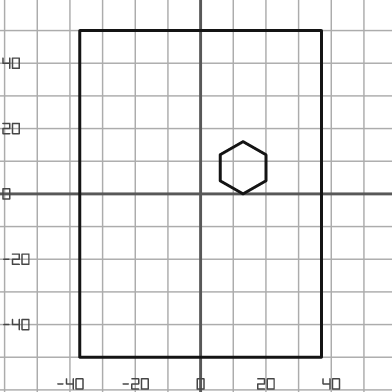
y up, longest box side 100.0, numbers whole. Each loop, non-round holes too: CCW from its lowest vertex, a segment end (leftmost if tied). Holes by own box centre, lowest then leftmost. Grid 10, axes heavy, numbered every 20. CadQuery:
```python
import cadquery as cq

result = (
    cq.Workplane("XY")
    .moveTo(-37.0, -50.0)
    .lineTo(37.0, -50.0)
    .lineTo(37.0, 50.0)
    .lineTo(-37.0, 50.0)
    .close()
    .moveTo(13.0, 0.0)
    .lineTo(20.0, 4.0)
    .lineTo(20.0, 12.0)
    .lineTo(13.0, 16.0)
    .lineTo(6.0, 12.0)
    .lineTo(6.0, 4.0)
    .close()
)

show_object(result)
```